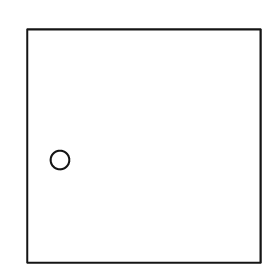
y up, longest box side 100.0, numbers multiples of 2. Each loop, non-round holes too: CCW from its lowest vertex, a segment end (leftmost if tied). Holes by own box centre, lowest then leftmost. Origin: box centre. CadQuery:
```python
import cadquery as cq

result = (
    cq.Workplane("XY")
    .moveTo(-50.0, -50.0)
    .lineTo(50.0, -50.0)
    .lineTo(50.0, 50.0)
    .lineTo(-50.0, 50.0)
    .close()
    .moveTo(-36.0, -6.0)
    .circle(4.0)
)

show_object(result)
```